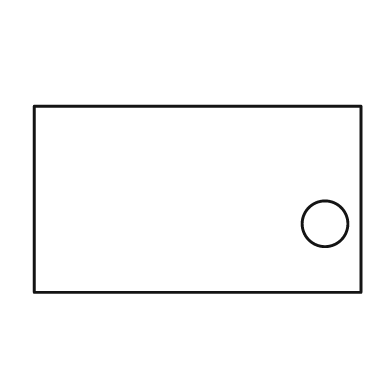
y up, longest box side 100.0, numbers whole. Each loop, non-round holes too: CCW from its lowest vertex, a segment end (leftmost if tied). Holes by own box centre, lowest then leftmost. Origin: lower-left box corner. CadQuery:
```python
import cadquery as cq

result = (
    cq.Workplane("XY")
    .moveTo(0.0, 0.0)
    .lineTo(100.0, 0.0)
    .lineTo(100.0, 57.0)
    .lineTo(0.0, 57.0)
    .close()
    .moveTo(89.0, 21.0)
    .circle(7.0)
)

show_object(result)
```